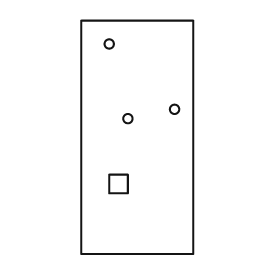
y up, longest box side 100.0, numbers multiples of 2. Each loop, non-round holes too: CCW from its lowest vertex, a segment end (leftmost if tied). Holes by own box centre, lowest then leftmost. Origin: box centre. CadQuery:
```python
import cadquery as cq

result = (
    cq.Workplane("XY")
    .moveTo(-24.0, -50.0)
    .lineTo(24.0, -50.0)
    .lineTo(24.0, 50.0)
    .lineTo(-24.0, 50.0)
    .close()
    .moveTo(-12.0, -24.0)
    .lineTo(-4.0, -24.0)
    .lineTo(-4.0, -16.0)
    .lineTo(-12.0, -16.0)
    .close()
    .moveTo(-4.0, 8.0)
    .circle(2.0)
    .moveTo(16.0, 12.0)
    .circle(2.0)
    .moveTo(-12.0, 40.0)
    .circle(2.0)
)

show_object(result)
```